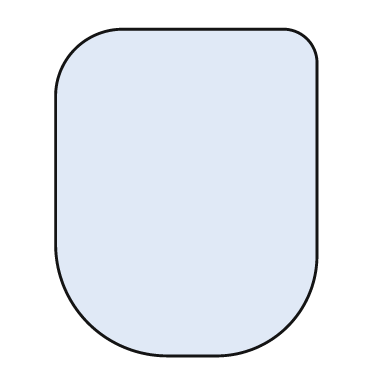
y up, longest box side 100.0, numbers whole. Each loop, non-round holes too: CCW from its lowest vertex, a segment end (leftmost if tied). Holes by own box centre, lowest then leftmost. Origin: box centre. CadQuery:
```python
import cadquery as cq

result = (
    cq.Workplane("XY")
    .moveTo(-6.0, -50.0)
    .lineTo(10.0, -50.0)
    .threePointArc((31.0, -41.0), (40.0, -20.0))
    .lineTo(40.0, 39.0)
    .threePointArc((37.0, 47.0), (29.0, 50.0))
    .lineTo(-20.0, 50.0)
    .threePointArc((-34.0, 44.0), (-40.0, 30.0))
    .lineTo(-40.0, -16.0)
    .threePointArc((-30.0, -40.0), (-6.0, -50.0))
    .close()
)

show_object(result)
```